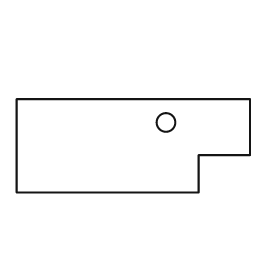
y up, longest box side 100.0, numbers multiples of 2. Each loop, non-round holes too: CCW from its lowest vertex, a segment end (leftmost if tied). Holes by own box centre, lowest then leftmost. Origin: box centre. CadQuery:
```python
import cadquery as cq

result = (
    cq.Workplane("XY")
    .moveTo(-50.0, -20.0)
    .lineTo(28.0, -20.0)
    .lineTo(28.0, -4.0)
    .lineTo(50.0, -4.0)
    .lineTo(50.0, 20.0)
    .lineTo(-50.0, 20.0)
    .close()
    .moveTo(14.0, 10.0)
    .circle(4.0)
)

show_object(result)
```